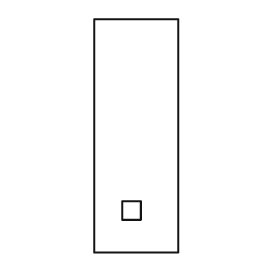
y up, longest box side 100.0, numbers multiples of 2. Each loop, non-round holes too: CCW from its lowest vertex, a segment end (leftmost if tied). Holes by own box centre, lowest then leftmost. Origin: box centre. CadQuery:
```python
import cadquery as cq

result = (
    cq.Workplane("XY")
    .moveTo(-18.0, -50.0)
    .lineTo(18.0, -50.0)
    .lineTo(18.0, 50.0)
    .lineTo(-18.0, 50.0)
    .close()
    .moveTo(-6.0, -36.0)
    .lineTo(2.0, -36.0)
    .lineTo(2.0, -28.0)
    .lineTo(-6.0, -28.0)
    .close()
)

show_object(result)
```